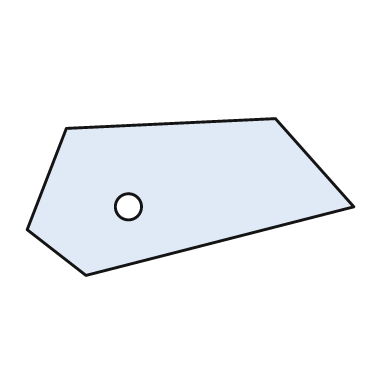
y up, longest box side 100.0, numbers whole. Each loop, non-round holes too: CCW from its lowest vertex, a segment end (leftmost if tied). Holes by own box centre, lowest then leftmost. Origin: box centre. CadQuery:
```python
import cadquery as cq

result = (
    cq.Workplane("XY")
    .moveTo(-32.0, -24.0)
    .lineTo(50.0, -3.0)
    .lineTo(26.0, 24.0)
    .lineTo(-38.0, 21.0)
    .lineTo(-50.0, -10.0)
    .close()
    .moveTo(-19.0, -3.0)
    .circle(4.0)
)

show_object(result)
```